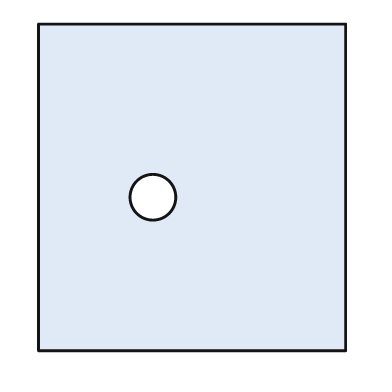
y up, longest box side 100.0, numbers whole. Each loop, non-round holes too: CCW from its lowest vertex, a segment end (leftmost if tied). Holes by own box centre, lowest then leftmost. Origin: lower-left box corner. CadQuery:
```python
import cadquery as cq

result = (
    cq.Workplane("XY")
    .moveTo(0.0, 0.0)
    .lineTo(94.0, 0.0)
    .lineTo(94.0, 100.0)
    .lineTo(0.0, 100.0)
    .close()
    .moveTo(35.0, 47.0)
    .circle(7.0)
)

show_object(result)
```